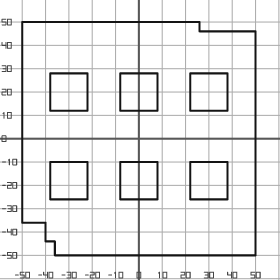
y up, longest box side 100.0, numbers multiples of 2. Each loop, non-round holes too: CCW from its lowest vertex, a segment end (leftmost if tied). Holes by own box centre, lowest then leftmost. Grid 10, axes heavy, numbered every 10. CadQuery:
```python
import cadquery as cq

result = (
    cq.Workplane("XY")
    .moveTo(-36.0, -50.0)
    .lineTo(50.0, -50.0)
    .lineTo(50.0, 46.0)
    .lineTo(26.0, 46.0)
    .lineTo(26.0, 50.0)
    .lineTo(-50.0, 50.0)
    .lineTo(-50.0, -36.0)
    .lineTo(-40.0, -36.0)
    .lineTo(-40.0, -44.0)
    .lineTo(-36.0, -44.0)
    .close()
    .moveTo(-38.0, -26.0)
    .lineTo(-22.0, -26.0)
    .lineTo(-22.0, -10.0)
    .lineTo(-38.0, -10.0)
    .close()
    .moveTo(-8.0, -26.0)
    .lineTo(8.0, -26.0)
    .lineTo(8.0, -10.0)
    .lineTo(-8.0, -10.0)
    .close()
    .moveTo(22.0, -26.0)
    .lineTo(38.0, -26.0)
    .lineTo(38.0, -10.0)
    .lineTo(22.0, -10.0)
    .close()
    .moveTo(-38.0, 12.0)
    .lineTo(-22.0, 12.0)
    .lineTo(-22.0, 28.0)
    .lineTo(-38.0, 28.0)
    .close()
    .moveTo(-8.0, 12.0)
    .lineTo(8.0, 12.0)
    .lineTo(8.0, 28.0)
    .lineTo(-8.0, 28.0)
    .close()
    .moveTo(22.0, 12.0)
    .lineTo(38.0, 12.0)
    .lineTo(38.0, 28.0)
    .lineTo(22.0, 28.0)
    .close()
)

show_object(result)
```